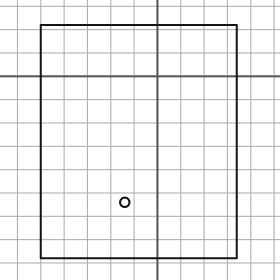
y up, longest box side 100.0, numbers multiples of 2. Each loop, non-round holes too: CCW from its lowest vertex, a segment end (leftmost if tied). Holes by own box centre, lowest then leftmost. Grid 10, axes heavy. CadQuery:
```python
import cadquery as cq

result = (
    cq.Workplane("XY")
    .moveTo(-50.0, -78.0)
    .lineTo(34.0, -78.0)
    .lineTo(34.0, 22.0)
    .lineTo(-50.0, 22.0)
    .close()
    .moveTo(-14.0, -54.0)
    .circle(2.0)
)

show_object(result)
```